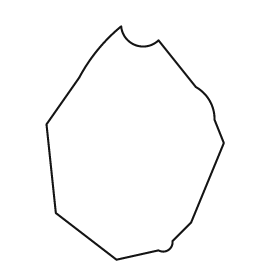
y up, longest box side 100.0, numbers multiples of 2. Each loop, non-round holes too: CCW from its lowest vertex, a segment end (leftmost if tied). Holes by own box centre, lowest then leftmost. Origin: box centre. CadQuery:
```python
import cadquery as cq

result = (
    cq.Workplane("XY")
    .moveTo(-8.0, -50.0)
    .lineTo(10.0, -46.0)
    .threePointArc((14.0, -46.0), (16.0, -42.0))
    .lineTo(24.0, -34.0)
    .lineTo(38.0, 0.0)
    .lineTo(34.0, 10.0)
    .threePointArc((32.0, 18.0), (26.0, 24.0))
    .lineTo(10.0, 44.0)
    .threePointArc((0.0, 42.0), (-6.0, 50.0))
    .threePointArc((-16.0, 40.0), (-24.0, 28.0))
    .lineTo(-38.0, 8.0)
    .lineTo(-34.0, -30.0)
    .close()
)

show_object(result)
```